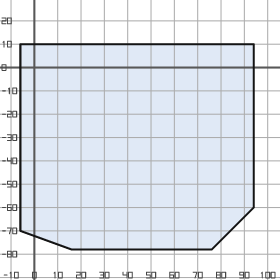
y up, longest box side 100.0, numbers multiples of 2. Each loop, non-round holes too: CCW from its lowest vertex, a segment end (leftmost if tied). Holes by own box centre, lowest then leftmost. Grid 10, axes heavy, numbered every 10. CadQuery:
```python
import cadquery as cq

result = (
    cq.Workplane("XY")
    .moveTo(16.0, -78.0)
    .lineTo(76.0, -78.0)
    .lineTo(94.0, -60.0)
    .lineTo(94.0, 10.0)
    .lineTo(-6.0, 10.0)
    .lineTo(-6.0, -70.0)
    .close()
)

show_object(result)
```